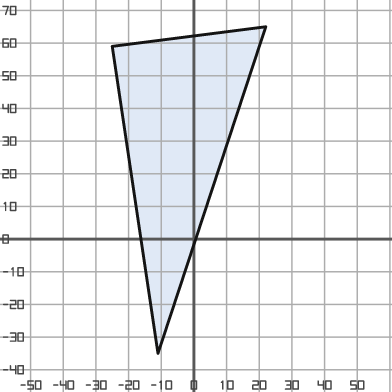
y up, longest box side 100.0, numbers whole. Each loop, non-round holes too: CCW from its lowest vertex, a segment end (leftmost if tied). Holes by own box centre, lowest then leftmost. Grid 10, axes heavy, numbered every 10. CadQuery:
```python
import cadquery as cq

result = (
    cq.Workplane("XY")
    .moveTo(-11.0, -35.0)
    .lineTo(22.0, 65.0)
    .lineTo(-25.0, 59.0)
    .close()
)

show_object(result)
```